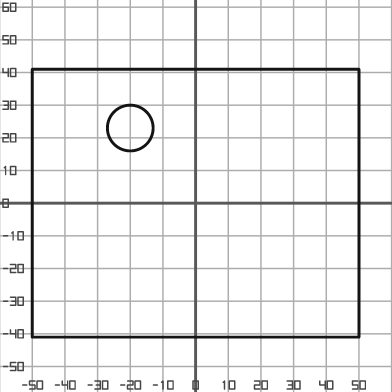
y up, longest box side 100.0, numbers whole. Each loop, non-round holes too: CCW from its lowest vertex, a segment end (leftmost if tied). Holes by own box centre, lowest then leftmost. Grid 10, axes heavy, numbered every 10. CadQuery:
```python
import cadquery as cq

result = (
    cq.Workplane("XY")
    .moveTo(-50.0, -41.0)
    .lineTo(50.0, -41.0)
    .lineTo(50.0, 41.0)
    .lineTo(-50.0, 41.0)
    .close()
    .moveTo(-20.0, 23.0)
    .circle(7.0)
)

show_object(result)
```